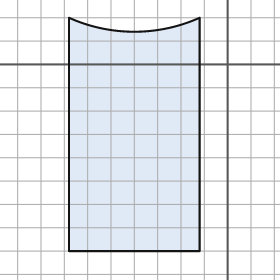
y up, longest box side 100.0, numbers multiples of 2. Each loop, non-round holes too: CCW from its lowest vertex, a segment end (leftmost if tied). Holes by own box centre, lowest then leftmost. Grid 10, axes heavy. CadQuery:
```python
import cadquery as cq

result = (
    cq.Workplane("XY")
    .moveTo(-68.0, -80.0)
    .lineTo(-12.0, -80.0)
    .lineTo(-12.0, 20.0)
    .threePointArc((-40.0, 14.0), (-68.0, 20.0))
    .close()
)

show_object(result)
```